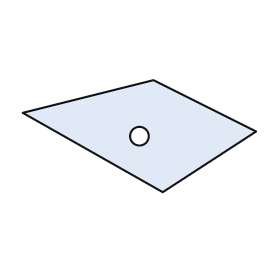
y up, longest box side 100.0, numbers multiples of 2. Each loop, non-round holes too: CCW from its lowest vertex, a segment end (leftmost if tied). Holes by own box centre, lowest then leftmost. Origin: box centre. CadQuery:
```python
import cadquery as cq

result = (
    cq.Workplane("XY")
    .moveTo(10.0, -24.0)
    .lineTo(50.0, 2.0)
    .lineTo(6.0, 24.0)
    .lineTo(-50.0, 10.0)
    .close()
    .moveTo(0.0, 0.0)
    .circle(4.0)
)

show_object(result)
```